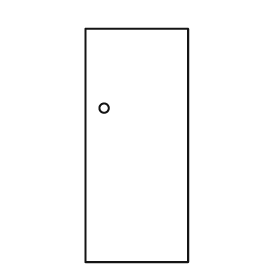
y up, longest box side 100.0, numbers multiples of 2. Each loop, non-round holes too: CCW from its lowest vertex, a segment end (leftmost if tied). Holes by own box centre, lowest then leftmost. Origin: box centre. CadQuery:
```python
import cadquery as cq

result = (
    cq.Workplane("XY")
    .moveTo(-22.0, -50.0)
    .lineTo(22.0, -50.0)
    .lineTo(22.0, 50.0)
    .lineTo(-22.0, 50.0)
    .close()
    .moveTo(-14.0, 16.0)
    .circle(2.0)
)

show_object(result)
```